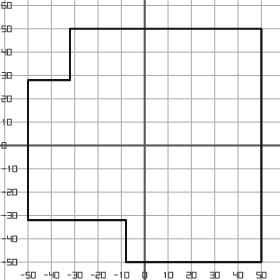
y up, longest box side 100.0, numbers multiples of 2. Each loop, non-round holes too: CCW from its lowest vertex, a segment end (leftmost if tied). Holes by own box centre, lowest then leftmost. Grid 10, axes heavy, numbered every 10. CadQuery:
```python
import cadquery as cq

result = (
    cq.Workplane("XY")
    .moveTo(-8.0, -50.0)
    .lineTo(50.0, -50.0)
    .lineTo(50.0, 50.0)
    .lineTo(-32.0, 50.0)
    .lineTo(-32.0, 28.0)
    .lineTo(-50.0, 28.0)
    .lineTo(-50.0, -32.0)
    .lineTo(-8.0, -32.0)
    .close()
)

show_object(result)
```